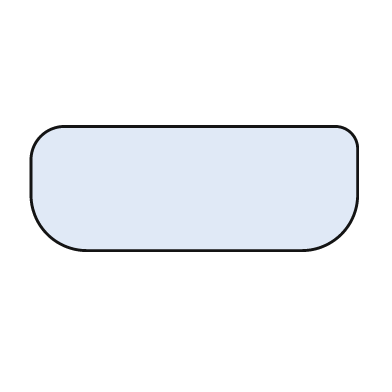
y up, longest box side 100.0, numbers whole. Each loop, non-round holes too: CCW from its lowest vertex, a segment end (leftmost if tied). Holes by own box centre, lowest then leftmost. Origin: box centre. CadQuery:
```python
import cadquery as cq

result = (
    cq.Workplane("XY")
    .moveTo(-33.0, -19.0)
    .lineTo(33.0, -19.0)
    .threePointArc((45.0, -14.0), (50.0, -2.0))
    .lineTo(50.0, 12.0)
    .threePointArc((48.0, 17.0), (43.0, 19.0))
    .lineTo(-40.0, 19.0)
    .threePointArc((-47.0, 16.0), (-50.0, 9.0))
    .lineTo(-50.0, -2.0)
    .threePointArc((-45.0, -14.0), (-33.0, -19.0))
    .close()
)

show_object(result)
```